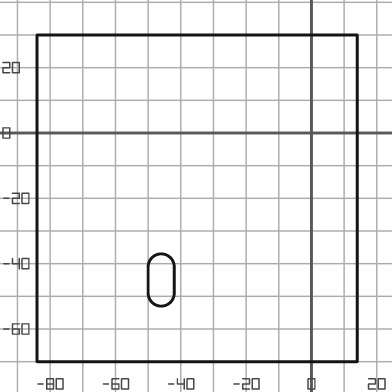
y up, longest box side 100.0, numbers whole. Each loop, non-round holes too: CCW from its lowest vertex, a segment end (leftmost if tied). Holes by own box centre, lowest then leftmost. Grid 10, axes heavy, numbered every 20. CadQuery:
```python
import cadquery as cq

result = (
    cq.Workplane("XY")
    .moveTo(-84.0, -70.0)
    .lineTo(14.0, -70.0)
    .lineTo(14.0, 30.0)
    .lineTo(-84.0, 30.0)
    .close()
    .moveTo(-50.0, -49.0)
    .threePointArc((-46.0, -53.0), (-42.0, -49.0))
    .lineTo(-42.0, -41.0)
    .threePointArc((-46.0, -37.0), (-50.0, -41.0))
    .close()
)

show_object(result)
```